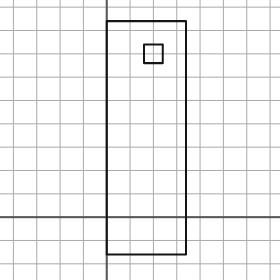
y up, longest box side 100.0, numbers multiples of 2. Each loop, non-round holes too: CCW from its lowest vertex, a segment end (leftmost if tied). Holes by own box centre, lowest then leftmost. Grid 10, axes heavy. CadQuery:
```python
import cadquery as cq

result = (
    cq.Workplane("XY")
    .moveTo(0.0, -16.0)
    .lineTo(34.0, -16.0)
    .lineTo(34.0, 84.0)
    .lineTo(0.0, 84.0)
    .close()
    .moveTo(16.0, 66.0)
    .lineTo(24.0, 66.0)
    .lineTo(24.0, 74.0)
    .lineTo(16.0, 74.0)
    .close()
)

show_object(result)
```